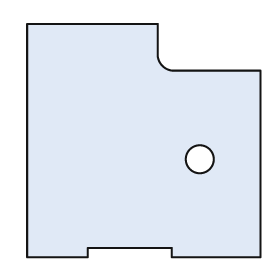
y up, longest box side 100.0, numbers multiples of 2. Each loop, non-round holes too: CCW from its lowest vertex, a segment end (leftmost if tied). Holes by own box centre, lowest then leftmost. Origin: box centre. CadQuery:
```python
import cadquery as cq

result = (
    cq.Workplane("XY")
    .moveTo(-50.0, -50.0)
    .lineTo(-24.0, -50.0)
    .lineTo(-24.0, -46.0)
    .lineTo(12.0, -46.0)
    .lineTo(12.0, -50.0)
    .lineTo(50.0, -50.0)
    .lineTo(50.0, 30.0)
    .lineTo(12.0, 30.0)
    .threePointArc((8.0, 32.0), (6.0, 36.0))
    .lineTo(6.0, 50.0)
    .lineTo(-50.0, 50.0)
    .close()
    .moveTo(24.0, -8.0)
    .circle(6.0)
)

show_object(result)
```